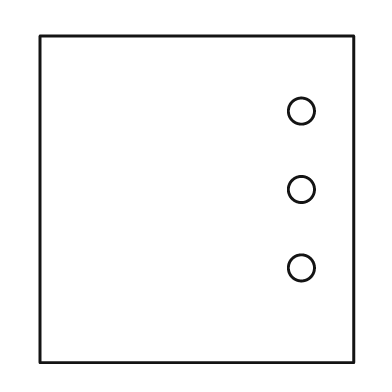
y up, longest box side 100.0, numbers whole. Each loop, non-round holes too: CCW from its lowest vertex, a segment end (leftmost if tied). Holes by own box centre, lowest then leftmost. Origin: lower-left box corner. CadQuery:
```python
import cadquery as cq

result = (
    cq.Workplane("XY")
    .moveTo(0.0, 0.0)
    .lineTo(96.0, 0.0)
    .lineTo(96.0, 100.0)
    .lineTo(0.0, 100.0)
    .close()
    .moveTo(80.0, 29.0)
    .circle(4.0)
    .moveTo(80.0, 53.0)
    .circle(4.0)
    .moveTo(80.0, 77.0)
    .circle(4.0)
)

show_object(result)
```